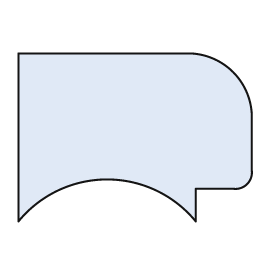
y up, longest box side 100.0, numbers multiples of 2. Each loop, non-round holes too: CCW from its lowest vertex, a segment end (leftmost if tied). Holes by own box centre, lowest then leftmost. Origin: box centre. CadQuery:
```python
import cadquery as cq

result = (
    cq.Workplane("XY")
    .moveTo(-50.0, -36.0)
    .threePointArc((-12.0, -18.0), (26.0, -36.0))
    .lineTo(26.0, -22.0)
    .lineTo(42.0, -22.0)
    .threePointArc((48.0, -20.0), (50.0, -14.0))
    .lineTo(50.0, 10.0)
    .threePointArc((42.0, 28.0), (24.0, 36.0))
    .lineTo(-50.0, 36.0)
    .close()
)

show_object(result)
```